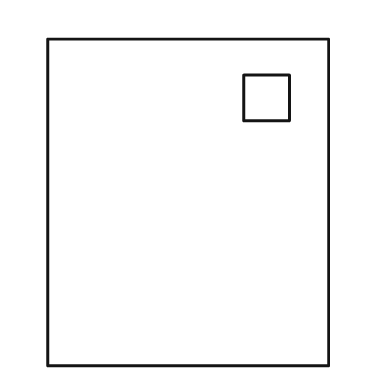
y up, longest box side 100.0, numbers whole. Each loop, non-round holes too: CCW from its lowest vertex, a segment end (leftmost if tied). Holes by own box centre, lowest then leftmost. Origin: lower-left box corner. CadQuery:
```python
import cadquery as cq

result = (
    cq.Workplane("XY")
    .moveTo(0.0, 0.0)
    .lineTo(86.0, 0.0)
    .lineTo(86.0, 100.0)
    .lineTo(0.0, 100.0)
    .close()
    .moveTo(60.0, 75.0)
    .lineTo(74.0, 75.0)
    .lineTo(74.0, 89.0)
    .lineTo(60.0, 89.0)
    .close()
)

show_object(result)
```